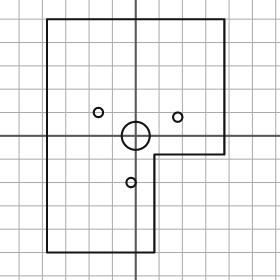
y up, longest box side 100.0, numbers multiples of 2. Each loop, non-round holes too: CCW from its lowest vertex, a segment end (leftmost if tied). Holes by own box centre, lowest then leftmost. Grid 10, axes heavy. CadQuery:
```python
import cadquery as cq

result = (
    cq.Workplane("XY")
    .moveTo(-38.0, -50.0)
    .lineTo(8.0, -50.0)
    .lineTo(8.0, -8.0)
    .lineTo(38.0, -8.0)
    .lineTo(38.0, 50.0)
    .lineTo(-38.0, 50.0)
    .close()
    .moveTo(-2.0, -20.0)
    .circle(2.0)
    .moveTo(0.0, 0.0)
    .circle(6.0)
    .moveTo(18.0, 8.0)
    .circle(2.0)
    .moveTo(-16.0, 10.0)
    .circle(2.0)
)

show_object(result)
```